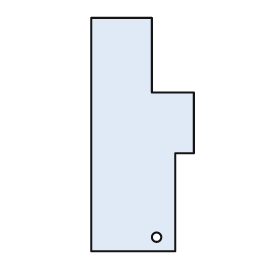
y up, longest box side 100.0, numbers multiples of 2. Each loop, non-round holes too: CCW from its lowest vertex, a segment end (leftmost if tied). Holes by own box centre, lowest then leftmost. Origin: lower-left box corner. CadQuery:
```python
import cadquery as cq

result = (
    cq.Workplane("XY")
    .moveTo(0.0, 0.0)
    .lineTo(36.0, 0.0)
    .lineTo(36.0, 42.0)
    .lineTo(44.0, 42.0)
    .lineTo(44.0, 68.0)
    .lineTo(26.0, 68.0)
    .lineTo(26.0, 100.0)
    .lineTo(0.0, 100.0)
    .close()
    .moveTo(28.0, 6.0)
    .circle(2.0)
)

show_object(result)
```